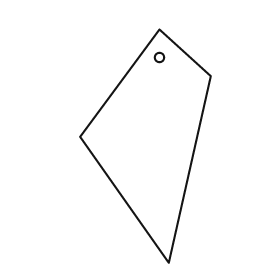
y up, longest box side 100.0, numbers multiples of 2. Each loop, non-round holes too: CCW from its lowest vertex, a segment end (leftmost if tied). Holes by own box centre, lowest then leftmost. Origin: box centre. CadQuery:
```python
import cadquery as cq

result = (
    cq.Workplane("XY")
    .moveTo(10.0, -50.0)
    .lineTo(28.0, 30.0)
    .lineTo(6.0, 50.0)
    .lineTo(-28.0, 4.0)
    .close()
    .moveTo(6.0, 38.0)
    .circle(2.0)
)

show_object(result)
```